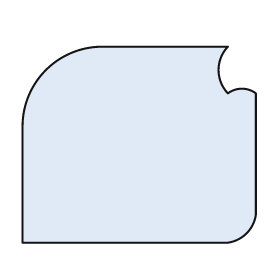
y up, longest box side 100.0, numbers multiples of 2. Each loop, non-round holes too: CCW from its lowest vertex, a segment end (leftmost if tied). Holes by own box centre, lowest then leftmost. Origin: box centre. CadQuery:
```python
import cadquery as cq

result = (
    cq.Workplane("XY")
    .moveTo(-50.0, -42.0)
    .lineTo(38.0, -42.0)
    .threePointArc((46.0, -38.0), (50.0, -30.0))
    .lineTo(50.0, 22.0)
    .threePointArc((44.0, 24.0), (38.0, 22.0))
    .threePointArc((34.0, 32.0), (38.0, 42.0))
    .lineTo(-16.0, 42.0)
    .threePointArc((-40.0, 32.0), (-50.0, 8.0))
    .close()
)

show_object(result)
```